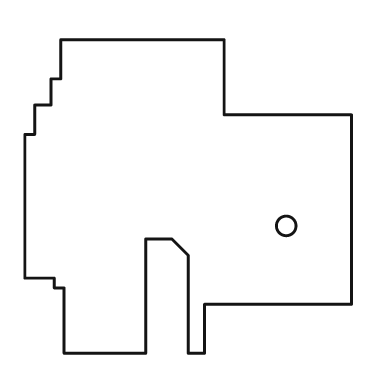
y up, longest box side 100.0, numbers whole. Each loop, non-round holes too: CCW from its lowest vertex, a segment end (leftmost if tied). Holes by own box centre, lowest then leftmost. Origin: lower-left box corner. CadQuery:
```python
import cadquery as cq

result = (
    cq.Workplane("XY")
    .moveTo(12.0, 0.0)
    .lineTo(37.0, 0.0)
    .lineTo(37.0, 35.0)
    .lineTo(45.0, 35.0)
    .lineTo(50.0, 30.0)
    .lineTo(50.0, 0.0)
    .lineTo(55.0, 0.0)
    .lineTo(55.0, 15.0)
    .lineTo(100.0, 15.0)
    .lineTo(100.0, 73.0)
    .lineTo(61.0, 73.0)
    .lineTo(61.0, 96.0)
    .lineTo(11.0, 96.0)
    .lineTo(11.0, 84.0)
    .lineTo(8.0, 84.0)
    .lineTo(8.0, 76.0)
    .lineTo(3.0, 76.0)
    .lineTo(3.0, 67.0)
    .lineTo(0.0, 67.0)
    .lineTo(0.0, 23.0)
    .lineTo(9.0, 23.0)
    .lineTo(9.0, 20.0)
    .lineTo(12.0, 20.0)
    .close()
    .moveTo(80.0, 39.0)
    .circle(3.0)
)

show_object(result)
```